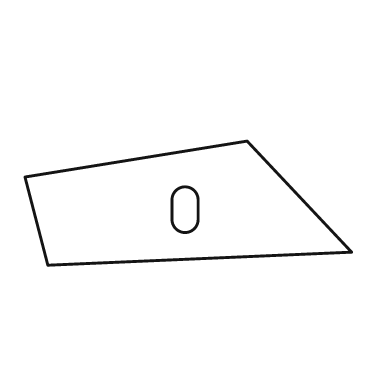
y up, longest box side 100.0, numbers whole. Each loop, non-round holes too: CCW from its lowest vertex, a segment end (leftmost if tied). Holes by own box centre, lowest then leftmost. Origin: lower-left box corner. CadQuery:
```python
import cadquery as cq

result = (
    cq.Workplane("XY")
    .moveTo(7.0, 0.0)
    .lineTo(100.0, 4.0)
    .lineTo(68.0, 38.0)
    .lineTo(0.0, 27.0)
    .close()
    .moveTo(45.0, 14.0)
    .threePointArc((49.0, 10.0), (53.0, 14.0))
    .lineTo(53.0, 20.0)
    .threePointArc((49.0, 24.0), (45.0, 20.0))
    .close()
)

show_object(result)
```